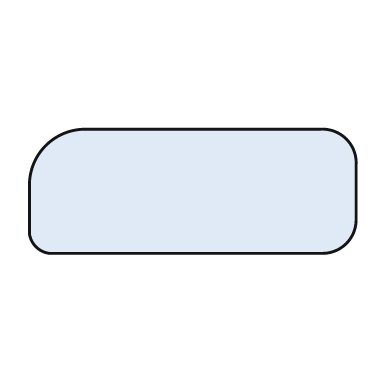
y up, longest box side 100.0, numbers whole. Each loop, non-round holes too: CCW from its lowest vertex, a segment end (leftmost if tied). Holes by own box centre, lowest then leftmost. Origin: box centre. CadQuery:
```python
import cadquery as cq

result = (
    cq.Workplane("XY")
    .moveTo(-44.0, -19.0)
    .lineTo(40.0, -19.0)
    .threePointArc((47.0, -16.0), (50.0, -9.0))
    .lineTo(50.0, 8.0)
    .threePointArc((47.0, 16.0), (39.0, 19.0))
    .lineTo(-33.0, 19.0)
    .threePointArc((-45.0, 14.0), (-50.0, 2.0))
    .lineTo(-50.0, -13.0)
    .threePointArc((-48.0, -17.0), (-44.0, -19.0))
    .close()
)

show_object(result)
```